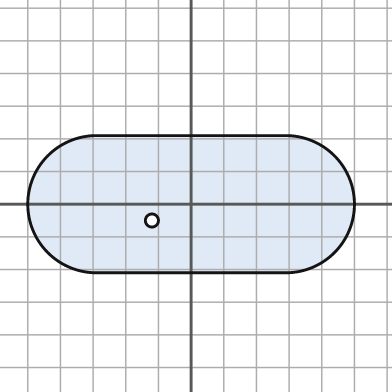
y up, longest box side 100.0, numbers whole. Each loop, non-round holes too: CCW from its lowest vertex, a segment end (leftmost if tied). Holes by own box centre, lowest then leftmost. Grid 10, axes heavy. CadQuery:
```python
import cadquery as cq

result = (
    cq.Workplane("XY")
    .moveTo(-29.0, -21.0)
    .lineTo(29.0, -21.0)
    .threePointArc((50.0, 0.0), (29.0, 21.0))
    .lineTo(-29.0, 21.0)
    .threePointArc((-50.0, 0.0), (-29.0, -21.0))
    .close()
    .moveTo(-12.0, -5.0)
    .circle(2.0)
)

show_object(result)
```